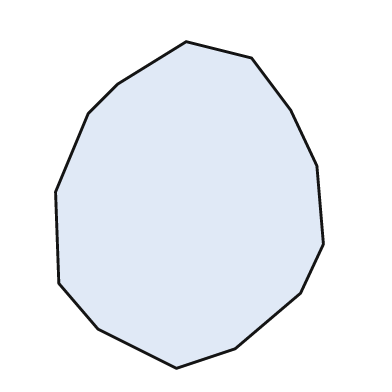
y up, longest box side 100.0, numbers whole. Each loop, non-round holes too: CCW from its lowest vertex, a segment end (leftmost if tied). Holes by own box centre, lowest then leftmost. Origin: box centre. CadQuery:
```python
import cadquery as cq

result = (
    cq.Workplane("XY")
    .moveTo(-4.0, -50.0)
    .lineTo(14.0, -44.0)
    .lineTo(34.0, -27.0)
    .lineTo(41.0, -12.0)
    .lineTo(39.0, 12.0)
    .lineTo(31.0, 29.0)
    .lineTo(19.0, 45.0)
    .lineTo(-1.0, 50.0)
    .lineTo(-22.0, 37.0)
    .lineTo(-31.0, 28.0)
    .lineTo(-41.0, 4.0)
    .lineTo(-40.0, -24.0)
    .lineTo(-28.0, -38.0)
    .close()
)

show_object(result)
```